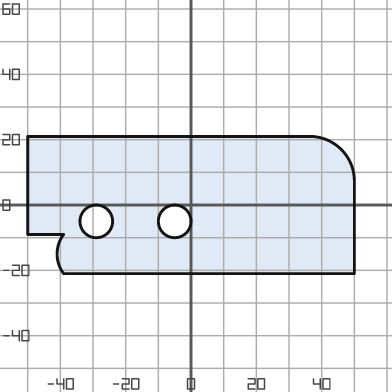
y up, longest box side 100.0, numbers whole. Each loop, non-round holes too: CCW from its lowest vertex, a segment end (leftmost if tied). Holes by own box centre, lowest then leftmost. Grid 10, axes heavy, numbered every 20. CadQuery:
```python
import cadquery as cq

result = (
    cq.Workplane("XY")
    .moveTo(-39.0, -21.0)
    .lineTo(50.0, -21.0)
    .lineTo(50.0, 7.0)
    .threePointArc((46.0, 17.0), (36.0, 21.0))
    .lineTo(-50.0, 21.0)
    .lineTo(-50.0, -9.0)
    .lineTo(-39.0, -9.0)
    .threePointArc((-41.0, -15.0), (-39.0, -21.0))
    .close()
    .moveTo(-29.0, -5.0)
    .circle(5.0)
    .moveTo(-5.0, -5.0)
    .circle(5.0)
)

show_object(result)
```